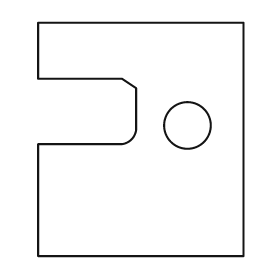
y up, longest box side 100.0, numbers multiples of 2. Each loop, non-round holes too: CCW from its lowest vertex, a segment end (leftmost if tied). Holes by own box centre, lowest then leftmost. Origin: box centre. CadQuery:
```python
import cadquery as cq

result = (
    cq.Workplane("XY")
    .moveTo(-44.0, -50.0)
    .lineTo(44.0, -50.0)
    .lineTo(44.0, 50.0)
    .lineTo(-44.0, 50.0)
    .lineTo(-44.0, 26.0)
    .lineTo(-8.0, 26.0)
    .lineTo(-2.0, 22.0)
    .lineTo(-2.0, 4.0)
    .threePointArc((-4.0, 0.0), (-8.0, -2.0))
    .lineTo(-44.0, -2.0)
    .close()
    .moveTo(20.0, 6.0)
    .circle(10.0)
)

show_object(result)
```